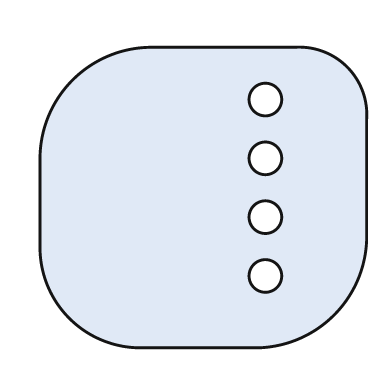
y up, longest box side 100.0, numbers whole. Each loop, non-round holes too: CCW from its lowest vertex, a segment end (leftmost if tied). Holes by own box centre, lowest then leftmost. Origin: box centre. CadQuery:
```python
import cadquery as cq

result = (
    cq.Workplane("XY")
    .moveTo(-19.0, -46.0)
    .lineTo(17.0, -46.0)
    .threePointArc((40.0, -36.0), (50.0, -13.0))
    .lineTo(50.0, 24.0)
    .threePointArc((44.0, 40.0), (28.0, 46.0))
    .lineTo(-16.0, 46.0)
    .threePointArc((-40.0, 36.0), (-50.0, 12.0))
    .lineTo(-50.0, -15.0)
    .threePointArc((-41.0, -37.0), (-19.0, -46.0))
    .close()
    .moveTo(19.0, -24.0)
    .circle(5.0)
    .moveTo(19.0, -6.0)
    .circle(5.0)
    .moveTo(19.0, 12.0)
    .circle(5.0)
    .moveTo(19.0, 30.0)
    .circle(5.0)
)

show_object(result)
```